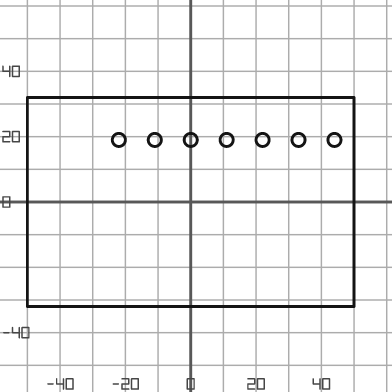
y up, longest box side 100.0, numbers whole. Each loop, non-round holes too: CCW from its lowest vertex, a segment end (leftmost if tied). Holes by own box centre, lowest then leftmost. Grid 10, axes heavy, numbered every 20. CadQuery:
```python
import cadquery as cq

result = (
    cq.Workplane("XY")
    .moveTo(-50.0, -32.0)
    .lineTo(50.0, -32.0)
    .lineTo(50.0, 32.0)
    .lineTo(-50.0, 32.0)
    .close()
    .moveTo(-22.0, 19.0)
    .circle(2.0)
    .moveTo(-11.0, 19.0)
    .circle(2.0)
    .moveTo(0.0, 19.0)
    .circle(2.0)
    .moveTo(11.0, 19.0)
    .circle(2.0)
    .moveTo(22.0, 19.0)
    .circle(2.0)
    .moveTo(33.0, 19.0)
    .circle(2.0)
    .moveTo(44.0, 19.0)
    .circle(2.0)
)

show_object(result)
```